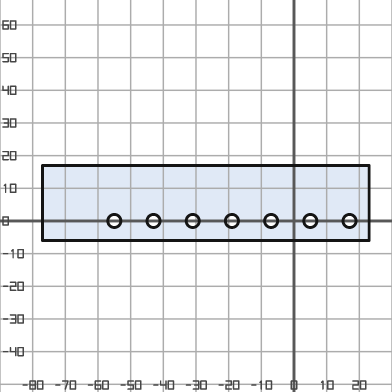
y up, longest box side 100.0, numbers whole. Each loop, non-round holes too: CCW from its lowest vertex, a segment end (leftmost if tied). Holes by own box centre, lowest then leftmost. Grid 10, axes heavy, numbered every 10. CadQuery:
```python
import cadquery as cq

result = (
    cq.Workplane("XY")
    .moveTo(-77.0, -6.0)
    .lineTo(23.0, -6.0)
    .lineTo(23.0, 17.0)
    .lineTo(-77.0, 17.0)
    .close()
    .moveTo(-55.0, 0.0)
    .circle(2.0)
    .moveTo(-43.0, 0.0)
    .circle(2.0)
    .moveTo(-31.0, 0.0)
    .circle(2.0)
    .moveTo(-19.0, 0.0)
    .circle(2.0)
    .moveTo(-7.0, 0.0)
    .circle(2.0)
    .moveTo(5.0, 0.0)
    .circle(2.0)
    .moveTo(17.0, 0.0)
    .circle(2.0)
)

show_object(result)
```